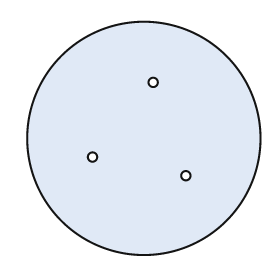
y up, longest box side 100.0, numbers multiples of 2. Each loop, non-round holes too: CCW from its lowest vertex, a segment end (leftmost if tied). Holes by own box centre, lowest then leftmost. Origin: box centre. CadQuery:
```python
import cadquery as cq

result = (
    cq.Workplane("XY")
    .moveTo(0.0, 0.0)
    .circle(50.0)
    .moveTo(18.0, -16.0)
    .circle(2.0)
    .moveTo(-22.0, -8.0)
    .circle(2.0)
    .moveTo(4.0, 24.0)
    .circle(2.0)
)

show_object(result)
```